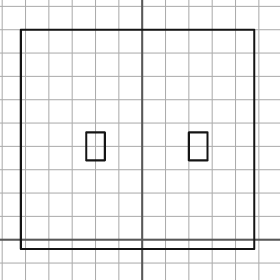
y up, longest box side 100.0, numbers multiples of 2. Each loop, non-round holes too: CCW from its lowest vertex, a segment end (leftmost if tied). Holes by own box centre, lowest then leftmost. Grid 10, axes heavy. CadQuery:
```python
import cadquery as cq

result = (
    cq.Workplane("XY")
    .moveTo(-52.0, -4.0)
    .lineTo(48.0, -4.0)
    .lineTo(48.0, 90.0)
    .lineTo(-52.0, 90.0)
    .close()
    .moveTo(-24.0, 34.0)
    .lineTo(-16.0, 34.0)
    .lineTo(-16.0, 46.0)
    .lineTo(-24.0, 46.0)
    .close()
    .moveTo(20.0, 34.0)
    .lineTo(28.0, 34.0)
    .lineTo(28.0, 46.0)
    .lineTo(20.0, 46.0)
    .close()
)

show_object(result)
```